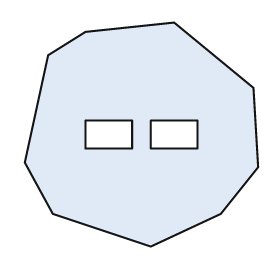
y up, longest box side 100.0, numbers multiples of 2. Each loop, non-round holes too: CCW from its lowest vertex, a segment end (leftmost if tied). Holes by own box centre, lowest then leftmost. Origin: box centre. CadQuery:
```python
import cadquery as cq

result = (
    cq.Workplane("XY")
    .moveTo(4.0, -48.0)
    .lineTo(34.0, -34.0)
    .lineTo(50.0, -14.0)
    .lineTo(48.0, 20.0)
    .lineTo(14.0, 48.0)
    .lineTo(-24.0, 44.0)
    .lineTo(-40.0, 34.0)
    .lineTo(-50.0, -12.0)
    .lineTo(-38.0, -34.0)
    .close()
    .moveTo(-24.0, -6.0)
    .lineTo(-4.0, -6.0)
    .lineTo(-4.0, 6.0)
    .lineTo(-24.0, 6.0)
    .close()
    .moveTo(4.0, -6.0)
    .lineTo(24.0, -6.0)
    .lineTo(24.0, 6.0)
    .lineTo(4.0, 6.0)
    .close()
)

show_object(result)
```